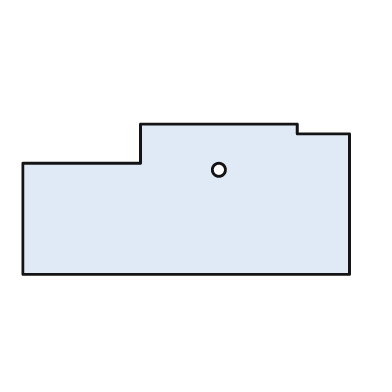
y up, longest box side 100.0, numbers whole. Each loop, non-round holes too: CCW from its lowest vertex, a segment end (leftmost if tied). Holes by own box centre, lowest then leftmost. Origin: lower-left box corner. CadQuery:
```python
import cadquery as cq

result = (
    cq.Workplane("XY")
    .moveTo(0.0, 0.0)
    .lineTo(100.0, 0.0)
    .lineTo(100.0, 43.0)
    .lineTo(84.0, 43.0)
    .lineTo(84.0, 46.0)
    .lineTo(36.0, 46.0)
    .lineTo(36.0, 34.0)
    .lineTo(0.0, 34.0)
    .close()
    .moveTo(60.0, 32.0)
    .circle(2.0)
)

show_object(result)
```